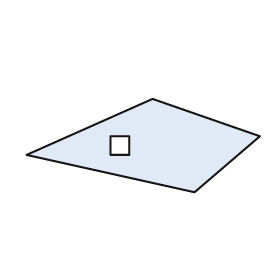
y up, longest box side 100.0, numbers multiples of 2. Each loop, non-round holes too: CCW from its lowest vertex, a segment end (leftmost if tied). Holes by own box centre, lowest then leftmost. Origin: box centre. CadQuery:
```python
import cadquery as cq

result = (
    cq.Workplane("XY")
    .moveTo(22.0, -20.0)
    .lineTo(50.0, 4.0)
    .lineTo(4.0, 20.0)
    .lineTo(-50.0, -4.0)
    .close()
    .moveTo(-14.0, -4.0)
    .lineTo(-6.0, -4.0)
    .lineTo(-6.0, 4.0)
    .lineTo(-14.0, 4.0)
    .close()
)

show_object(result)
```